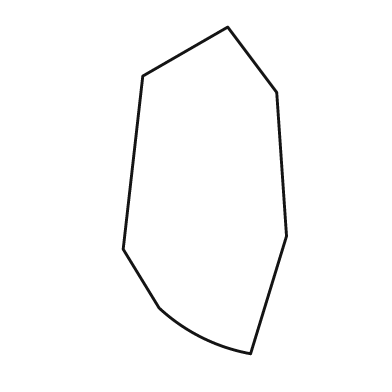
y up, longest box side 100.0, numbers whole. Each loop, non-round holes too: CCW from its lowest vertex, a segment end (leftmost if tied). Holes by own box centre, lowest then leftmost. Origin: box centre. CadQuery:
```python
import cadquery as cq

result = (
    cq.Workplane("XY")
    .moveTo(14.0, -50.0)
    .lineTo(25.0, -14.0)
    .lineTo(22.0, 30.0)
    .lineTo(7.0, 50.0)
    .lineTo(-19.0, 35.0)
    .lineTo(-25.0, -18.0)
    .lineTo(-14.0, -36.0)
    .threePointArc((-1.0, -45.0), (14.0, -50.0))
    .close()
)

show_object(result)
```